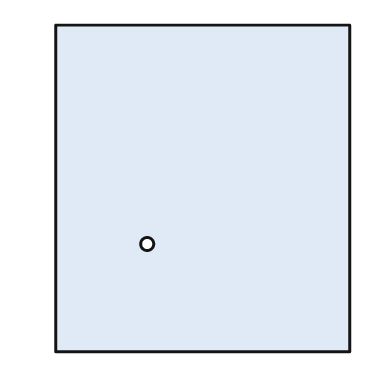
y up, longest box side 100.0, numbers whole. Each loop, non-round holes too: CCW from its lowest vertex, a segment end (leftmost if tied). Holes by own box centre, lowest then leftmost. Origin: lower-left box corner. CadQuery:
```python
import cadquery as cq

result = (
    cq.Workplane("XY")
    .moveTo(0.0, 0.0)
    .lineTo(90.0, 0.0)
    .lineTo(90.0, 100.0)
    .lineTo(0.0, 100.0)
    .close()
    .moveTo(28.0, 33.0)
    .circle(2.0)
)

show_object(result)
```